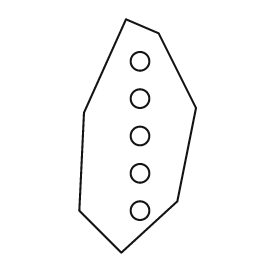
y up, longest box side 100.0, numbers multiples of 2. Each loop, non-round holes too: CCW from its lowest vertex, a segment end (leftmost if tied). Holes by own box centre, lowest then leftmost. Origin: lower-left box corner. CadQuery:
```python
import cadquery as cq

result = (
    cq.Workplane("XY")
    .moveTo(18.0, 0.0)
    .lineTo(42.0, 22.0)
    .lineTo(50.0, 62.0)
    .lineTo(34.0, 94.0)
    .lineTo(20.0, 100.0)
    .lineTo(2.0, 60.0)
    .lineTo(0.0, 18.0)
    .close()
    .moveTo(26.0, 18.0)
    .circle(4.0)
    .moveTo(26.0, 34.0)
    .circle(4.0)
    .moveTo(26.0, 50.0)
    .circle(4.0)
    .moveTo(26.0, 66.0)
    .circle(4.0)
    .moveTo(26.0, 82.0)
    .circle(4.0)
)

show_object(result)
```